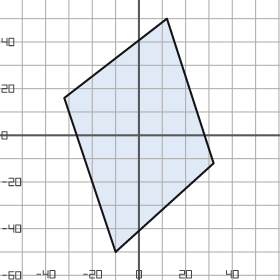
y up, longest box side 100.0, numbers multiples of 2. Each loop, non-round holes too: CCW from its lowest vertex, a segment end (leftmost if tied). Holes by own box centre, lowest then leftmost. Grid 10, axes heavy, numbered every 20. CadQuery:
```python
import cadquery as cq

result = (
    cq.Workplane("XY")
    .moveTo(-10.0, -50.0)
    .lineTo(32.0, -12.0)
    .lineTo(12.0, 50.0)
    .lineTo(-32.0, 16.0)
    .close()
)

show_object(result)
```